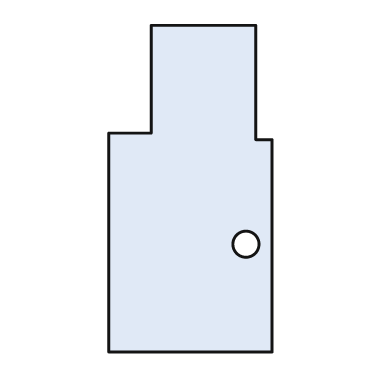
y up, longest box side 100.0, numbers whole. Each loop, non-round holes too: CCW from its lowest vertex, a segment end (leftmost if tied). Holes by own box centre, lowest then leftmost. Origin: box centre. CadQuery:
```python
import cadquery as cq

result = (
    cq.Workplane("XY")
    .moveTo(-25.0, -50.0)
    .lineTo(25.0, -50.0)
    .lineTo(25.0, 15.0)
    .lineTo(20.0, 15.0)
    .lineTo(20.0, 50.0)
    .lineTo(-12.0, 50.0)
    .lineTo(-12.0, 17.0)
    .lineTo(-25.0, 17.0)
    .close()
    .moveTo(17.0, -17.0)
    .circle(4.0)
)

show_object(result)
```